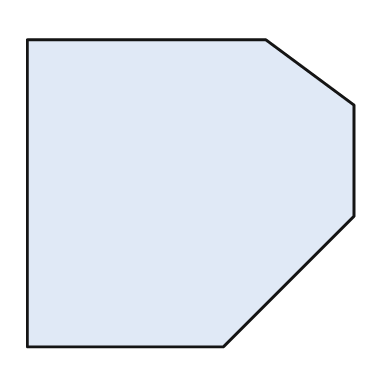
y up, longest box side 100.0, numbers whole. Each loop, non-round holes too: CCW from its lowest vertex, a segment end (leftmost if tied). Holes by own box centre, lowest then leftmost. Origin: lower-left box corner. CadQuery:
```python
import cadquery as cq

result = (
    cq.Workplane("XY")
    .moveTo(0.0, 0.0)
    .lineTo(60.0, 0.0)
    .lineTo(100.0, 40.0)
    .lineTo(100.0, 74.0)
    .lineTo(73.0, 94.0)
    .lineTo(0.0, 94.0)
    .close()
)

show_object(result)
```